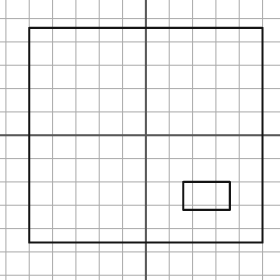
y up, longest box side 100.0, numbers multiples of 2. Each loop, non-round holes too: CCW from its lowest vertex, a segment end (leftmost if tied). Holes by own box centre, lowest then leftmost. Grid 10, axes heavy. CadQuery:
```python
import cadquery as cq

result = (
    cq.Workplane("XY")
    .moveTo(-50.0, -46.0)
    .lineTo(50.0, -46.0)
    .lineTo(50.0, 46.0)
    .lineTo(-50.0, 46.0)
    .close()
    .moveTo(16.0, -32.0)
    .lineTo(36.0, -32.0)
    .lineTo(36.0, -20.0)
    .lineTo(16.0, -20.0)
    .close()
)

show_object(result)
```